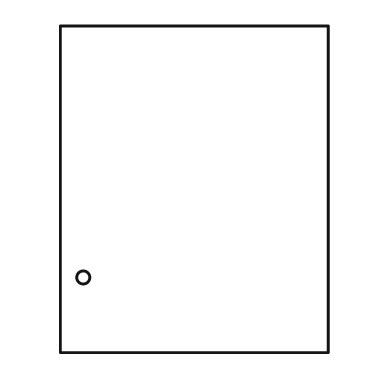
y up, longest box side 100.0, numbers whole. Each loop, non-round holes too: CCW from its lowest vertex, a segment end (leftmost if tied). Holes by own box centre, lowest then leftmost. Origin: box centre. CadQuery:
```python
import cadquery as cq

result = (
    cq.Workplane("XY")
    .moveTo(-41.0, -50.0)
    .lineTo(41.0, -50.0)
    .lineTo(41.0, 50.0)
    .lineTo(-41.0, 50.0)
    .close()
    .moveTo(-34.0, -27.0)
    .circle(2.0)
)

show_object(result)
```